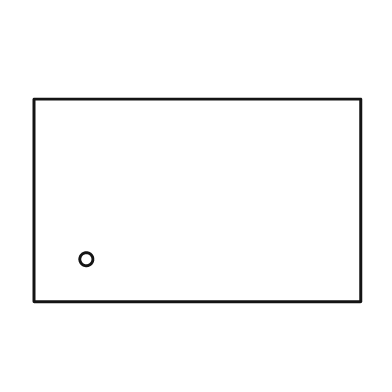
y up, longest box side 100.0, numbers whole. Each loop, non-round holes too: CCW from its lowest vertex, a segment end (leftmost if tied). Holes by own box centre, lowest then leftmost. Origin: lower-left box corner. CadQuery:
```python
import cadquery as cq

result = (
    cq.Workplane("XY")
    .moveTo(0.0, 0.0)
    .lineTo(100.0, 0.0)
    .lineTo(100.0, 62.0)
    .lineTo(0.0, 62.0)
    .close()
    .moveTo(16.0, 13.0)
    .circle(2.0)
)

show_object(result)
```